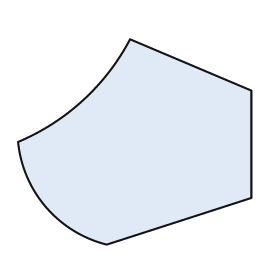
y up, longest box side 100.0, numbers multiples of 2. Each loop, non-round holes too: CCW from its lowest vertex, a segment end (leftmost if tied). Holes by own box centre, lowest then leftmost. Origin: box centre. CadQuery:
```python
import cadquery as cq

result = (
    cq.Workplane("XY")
    .moveTo(-12.0, -44.0)
    .lineTo(50.0, -24.0)
    .lineTo(50.0, 22.0)
    .lineTo(-2.0, 44.0)
    .threePointArc((-22.0, 18.0), (-50.0, 0.0))
    .threePointArc((-38.0, -28.0), (-12.0, -44.0))
    .close()
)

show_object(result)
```